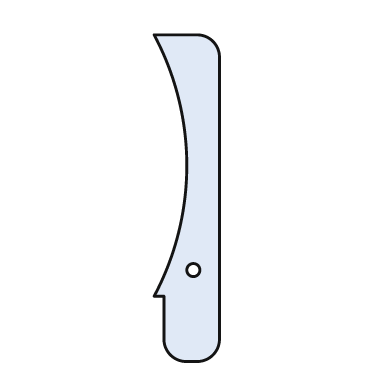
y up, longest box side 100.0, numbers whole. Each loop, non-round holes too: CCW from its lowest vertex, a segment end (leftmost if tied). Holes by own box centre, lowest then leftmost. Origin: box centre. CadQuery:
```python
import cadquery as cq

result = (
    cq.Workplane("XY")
    .moveTo(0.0, -50.0)
    .lineTo(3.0, -50.0)
    .threePointArc((8.0, -48.0), (10.0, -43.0))
    .lineTo(10.0, 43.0)
    .threePointArc((8.0, 48.0), (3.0, 50.0))
    .lineTo(-10.0, 50.0)
    .threePointArc((0.0, 10.0), (-10.0, -30.0))
    .lineTo(-7.0, -30.0)
    .lineTo(-7.0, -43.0)
    .threePointArc((-5.0, -48.0), (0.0, -50.0))
    .close()
    .moveTo(2.0, -22.0)
    .circle(2.0)
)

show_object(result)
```